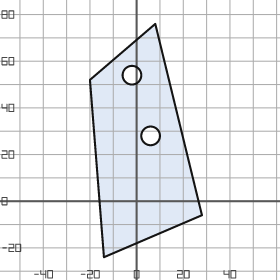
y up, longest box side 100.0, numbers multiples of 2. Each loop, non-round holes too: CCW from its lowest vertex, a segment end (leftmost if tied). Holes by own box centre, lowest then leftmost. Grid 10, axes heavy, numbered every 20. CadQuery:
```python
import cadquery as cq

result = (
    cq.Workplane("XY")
    .moveTo(-14.0, -24.0)
    .lineTo(28.0, -6.0)
    .lineTo(8.0, 76.0)
    .lineTo(-20.0, 52.0)
    .close()
    .moveTo(6.0, 28.0)
    .circle(4.0)
    .moveTo(-2.0, 54.0)
    .circle(4.0)
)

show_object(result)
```